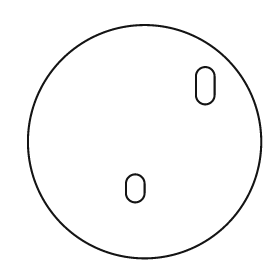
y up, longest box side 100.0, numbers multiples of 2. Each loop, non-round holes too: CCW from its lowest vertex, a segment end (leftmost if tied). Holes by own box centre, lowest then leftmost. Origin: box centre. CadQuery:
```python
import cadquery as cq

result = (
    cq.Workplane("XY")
    .moveTo(0.0, 0.0)
    .circle(50.0)
    .moveTo(-8.0, -22.0)
    .threePointArc((-4.0, -26.0), (0.0, -22.0))
    .lineTo(0.0, -18.0)
    .threePointArc((-4.0, -14.0), (-8.0, -18.0))
    .close()
    .moveTo(22.0, 20.0)
    .threePointArc((26.0, 16.0), (30.0, 20.0))
    .lineTo(30.0, 28.0)
    .threePointArc((26.0, 32.0), (22.0, 28.0))
    .close()
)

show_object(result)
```